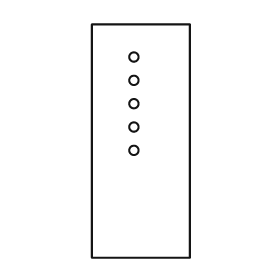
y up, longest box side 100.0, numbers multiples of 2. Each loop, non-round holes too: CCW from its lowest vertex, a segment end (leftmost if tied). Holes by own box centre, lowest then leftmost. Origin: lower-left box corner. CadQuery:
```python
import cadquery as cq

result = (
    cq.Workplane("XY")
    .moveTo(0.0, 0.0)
    .lineTo(42.0, 0.0)
    .lineTo(42.0, 100.0)
    .lineTo(0.0, 100.0)
    .close()
    .moveTo(18.0, 46.0)
    .circle(2.0)
    .moveTo(18.0, 56.0)
    .circle(2.0)
    .moveTo(18.0, 66.0)
    .circle(2.0)
    .moveTo(18.0, 76.0)
    .circle(2.0)
    .moveTo(18.0, 86.0)
    .circle(2.0)
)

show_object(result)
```